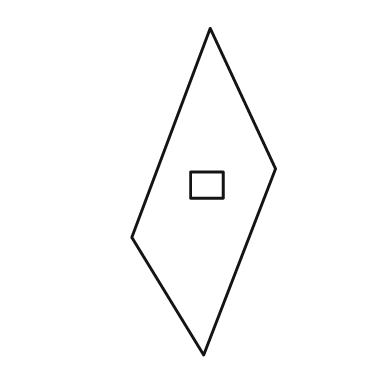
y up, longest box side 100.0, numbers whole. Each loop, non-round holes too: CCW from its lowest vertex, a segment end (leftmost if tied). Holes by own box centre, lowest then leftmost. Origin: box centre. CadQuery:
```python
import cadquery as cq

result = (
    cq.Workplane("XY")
    .moveTo(0.0, -50.0)
    .lineTo(22.0, 7.0)
    .lineTo(2.0, 50.0)
    .lineTo(-22.0, -14.0)
    .close()
    .moveTo(-4.0, -2.0)
    .lineTo(6.0, -2.0)
    .lineTo(6.0, 6.0)
    .lineTo(-4.0, 6.0)
    .close()
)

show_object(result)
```